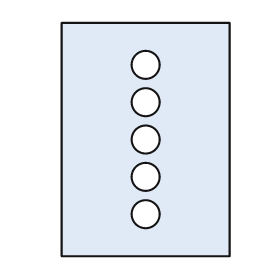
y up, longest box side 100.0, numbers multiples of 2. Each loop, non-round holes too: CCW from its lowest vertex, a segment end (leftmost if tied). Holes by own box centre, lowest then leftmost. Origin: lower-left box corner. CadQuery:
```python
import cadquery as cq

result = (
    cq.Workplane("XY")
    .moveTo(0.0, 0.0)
    .lineTo(72.0, 0.0)
    .lineTo(72.0, 100.0)
    .lineTo(0.0, 100.0)
    .close()
    .moveTo(36.0, 18.0)
    .circle(6.0)
    .moveTo(36.0, 34.0)
    .circle(6.0)
    .moveTo(36.0, 50.0)
    .circle(6.0)
    .moveTo(36.0, 66.0)
    .circle(6.0)
    .moveTo(36.0, 82.0)
    .circle(6.0)
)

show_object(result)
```